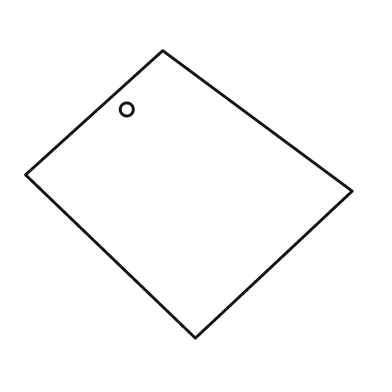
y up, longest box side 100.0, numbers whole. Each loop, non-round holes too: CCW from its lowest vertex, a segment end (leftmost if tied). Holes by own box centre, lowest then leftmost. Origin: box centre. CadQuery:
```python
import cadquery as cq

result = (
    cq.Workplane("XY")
    .moveTo(2.0, -44.0)
    .lineTo(50.0, 1.0)
    .lineTo(-8.0, 44.0)
    .lineTo(-50.0, 6.0)
    .close()
    .moveTo(-19.0, 26.0)
    .circle(2.0)
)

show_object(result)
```